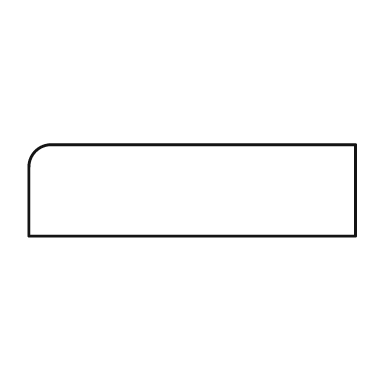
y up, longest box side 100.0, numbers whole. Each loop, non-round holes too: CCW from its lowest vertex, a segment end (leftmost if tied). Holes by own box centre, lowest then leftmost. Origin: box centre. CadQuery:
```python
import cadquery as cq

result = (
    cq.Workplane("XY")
    .moveTo(-50.0, -14.0)
    .lineTo(50.0, -14.0)
    .lineTo(50.0, 14.0)
    .lineTo(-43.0, 14.0)
    .threePointArc((-48.0, 12.0), (-50.0, 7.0))
    .close()
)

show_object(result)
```